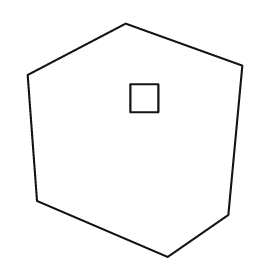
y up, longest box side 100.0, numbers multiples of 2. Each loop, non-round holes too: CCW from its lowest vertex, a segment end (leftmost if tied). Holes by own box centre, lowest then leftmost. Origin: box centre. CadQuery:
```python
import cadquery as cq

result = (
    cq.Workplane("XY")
    .moveTo(14.0, -50.0)
    .lineTo(40.0, -32.0)
    .lineTo(46.0, 32.0)
    .lineTo(-4.0, 50.0)
    .lineTo(-46.0, 28.0)
    .lineTo(-42.0, -26.0)
    .close()
    .moveTo(-2.0, 12.0)
    .lineTo(10.0, 12.0)
    .lineTo(10.0, 24.0)
    .lineTo(-2.0, 24.0)
    .close()
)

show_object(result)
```